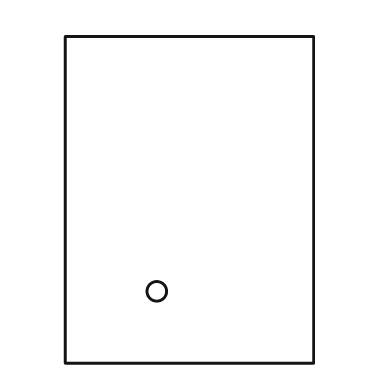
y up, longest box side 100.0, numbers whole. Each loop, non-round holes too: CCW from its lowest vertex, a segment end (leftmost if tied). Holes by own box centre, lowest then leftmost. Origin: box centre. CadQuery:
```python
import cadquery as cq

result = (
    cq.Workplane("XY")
    .moveTo(-38.0, -50.0)
    .lineTo(38.0, -50.0)
    .lineTo(38.0, 50.0)
    .lineTo(-38.0, 50.0)
    .close()
    .moveTo(-10.0, -28.0)
    .circle(3.0)
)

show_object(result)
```